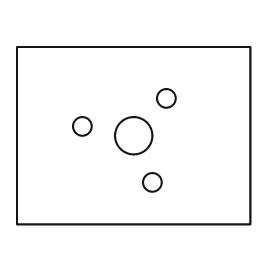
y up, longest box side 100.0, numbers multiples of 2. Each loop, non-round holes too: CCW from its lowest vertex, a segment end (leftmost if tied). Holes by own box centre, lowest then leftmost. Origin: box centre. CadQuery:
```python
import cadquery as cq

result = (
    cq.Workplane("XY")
    .moveTo(-50.0, -38.0)
    .lineTo(50.0, -38.0)
    .lineTo(50.0, 38.0)
    .lineTo(-50.0, 38.0)
    .close()
    .moveTo(8.0, -20.0)
    .circle(4.0)
    .moveTo(0.0, 0.0)
    .circle(8.0)
    .moveTo(-22.0, 4.0)
    .circle(4.0)
    .moveTo(14.0, 16.0)
    .circle(4.0)
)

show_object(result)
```